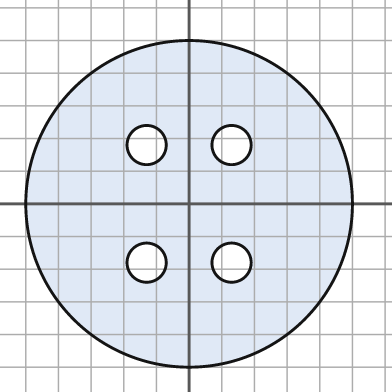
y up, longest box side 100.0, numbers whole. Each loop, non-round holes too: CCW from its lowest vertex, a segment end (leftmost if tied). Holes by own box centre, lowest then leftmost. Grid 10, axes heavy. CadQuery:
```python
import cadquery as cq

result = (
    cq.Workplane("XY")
    .moveTo(0.0, 0.0)
    .circle(50.0)
    .moveTo(-13.0, -18.0)
    .circle(6.0)
    .moveTo(13.0, -18.0)
    .circle(6.0)
    .moveTo(-13.0, 18.0)
    .circle(6.0)
    .moveTo(13.0, 18.0)
    .circle(6.0)
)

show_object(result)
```